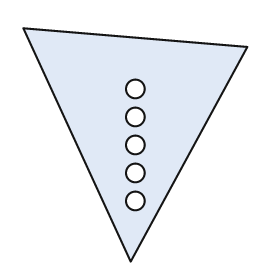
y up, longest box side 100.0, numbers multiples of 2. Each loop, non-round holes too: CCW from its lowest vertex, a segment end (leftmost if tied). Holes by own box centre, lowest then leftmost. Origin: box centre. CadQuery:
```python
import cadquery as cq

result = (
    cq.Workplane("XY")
    .moveTo(-2.0, -50.0)
    .lineTo(48.0, 42.0)
    .lineTo(-48.0, 50.0)
    .close()
    .moveTo(0.0, -24.0)
    .circle(4.0)
    .moveTo(0.0, -12.0)
    .circle(4.0)
    .moveTo(0.0, 0.0)
    .circle(4.0)
    .moveTo(0.0, 12.0)
    .circle(4.0)
    .moveTo(0.0, 24.0)
    .circle(4.0)
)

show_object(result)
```